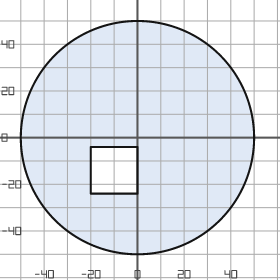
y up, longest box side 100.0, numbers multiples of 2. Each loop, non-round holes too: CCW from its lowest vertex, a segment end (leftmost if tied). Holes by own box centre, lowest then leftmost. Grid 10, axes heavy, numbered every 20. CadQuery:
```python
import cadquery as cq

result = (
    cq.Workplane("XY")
    .moveTo(0.0, 0.0)
    .circle(50.0)
    .moveTo(-20.0, -24.0)
    .lineTo(0.0, -24.0)
    .lineTo(0.0, -4.0)
    .lineTo(-20.0, -4.0)
    .close()
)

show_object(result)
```